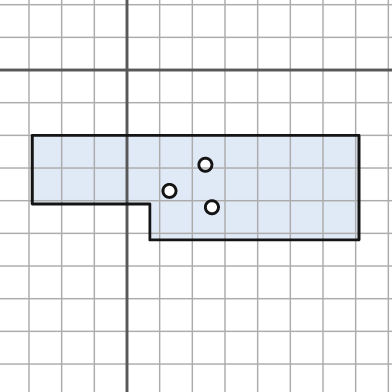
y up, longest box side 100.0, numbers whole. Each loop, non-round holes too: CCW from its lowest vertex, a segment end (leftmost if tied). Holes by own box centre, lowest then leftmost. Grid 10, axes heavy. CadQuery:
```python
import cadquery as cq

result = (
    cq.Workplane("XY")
    .moveTo(7.0, -52.0)
    .lineTo(71.0, -52.0)
    .lineTo(71.0, -20.0)
    .lineTo(-29.0, -20.0)
    .lineTo(-29.0, -41.0)
    .lineTo(7.0, -41.0)
    .close()
    .moveTo(26.0, -42.0)
    .circle(2.0)
    .moveTo(13.0, -37.0)
    .circle(2.0)
    .moveTo(24.0, -29.0)
    .circle(2.0)
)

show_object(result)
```